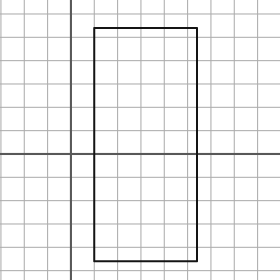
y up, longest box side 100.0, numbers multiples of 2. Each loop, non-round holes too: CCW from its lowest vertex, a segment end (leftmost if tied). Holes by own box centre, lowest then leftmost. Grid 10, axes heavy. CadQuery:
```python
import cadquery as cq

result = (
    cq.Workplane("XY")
    .moveTo(10.0, -46.0)
    .lineTo(54.0, -46.0)
    .lineTo(54.0, 54.0)
    .lineTo(10.0, 54.0)
    .close()
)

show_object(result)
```